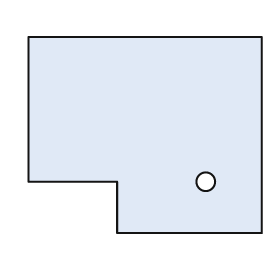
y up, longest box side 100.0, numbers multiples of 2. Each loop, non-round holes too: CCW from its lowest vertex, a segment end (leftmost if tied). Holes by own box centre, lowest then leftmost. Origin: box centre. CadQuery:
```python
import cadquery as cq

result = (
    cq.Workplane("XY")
    .moveTo(-12.0, -42.0)
    .lineTo(50.0, -42.0)
    .lineTo(50.0, 42.0)
    .lineTo(-50.0, 42.0)
    .lineTo(-50.0, -20.0)
    .lineTo(-12.0, -20.0)
    .close()
    .moveTo(26.0, -20.0)
    .circle(4.0)
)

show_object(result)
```